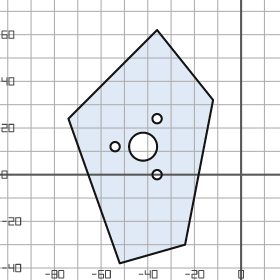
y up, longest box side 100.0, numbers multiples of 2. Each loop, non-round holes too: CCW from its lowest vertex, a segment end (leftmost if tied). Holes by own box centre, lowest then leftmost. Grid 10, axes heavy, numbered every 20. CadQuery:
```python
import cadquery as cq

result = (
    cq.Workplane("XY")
    .moveTo(-52.0, -38.0)
    .lineTo(-24.0, -30.0)
    .lineTo(-12.0, 32.0)
    .lineTo(-36.0, 62.0)
    .lineTo(-74.0, 24.0)
    .close()
    .moveTo(-36.0, 0.0)
    .circle(2.0)
    .moveTo(-54.0, 12.0)
    .circle(2.0)
    .moveTo(-42.0, 12.0)
    .circle(6.0)
    .moveTo(-36.0, 24.0)
    .circle(2.0)
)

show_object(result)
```